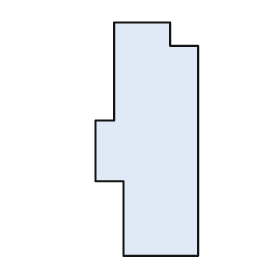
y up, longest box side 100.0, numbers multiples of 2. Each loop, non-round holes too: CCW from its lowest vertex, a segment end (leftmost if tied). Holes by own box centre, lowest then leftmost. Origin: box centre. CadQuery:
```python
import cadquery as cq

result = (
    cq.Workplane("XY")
    .moveTo(-10.0, -50.0)
    .lineTo(22.0, -50.0)
    .lineTo(22.0, 40.0)
    .lineTo(10.0, 40.0)
    .lineTo(10.0, 50.0)
    .lineTo(-14.0, 50.0)
    .lineTo(-14.0, 8.0)
    .lineTo(-22.0, 8.0)
    .lineTo(-22.0, -18.0)
    .lineTo(-10.0, -18.0)
    .close()
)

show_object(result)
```